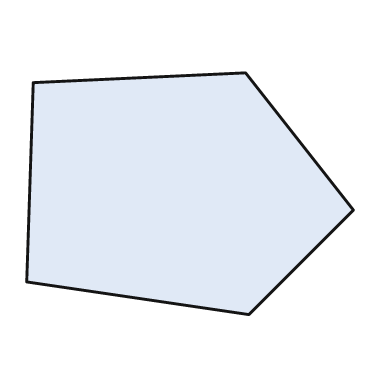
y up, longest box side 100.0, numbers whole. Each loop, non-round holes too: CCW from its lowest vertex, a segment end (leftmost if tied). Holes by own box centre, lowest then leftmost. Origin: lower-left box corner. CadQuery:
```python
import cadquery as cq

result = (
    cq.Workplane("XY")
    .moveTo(68.0, 0.0)
    .lineTo(100.0, 32.0)
    .lineTo(67.0, 74.0)
    .lineTo(2.0, 71.0)
    .lineTo(0.0, 10.0)
    .close()
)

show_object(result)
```